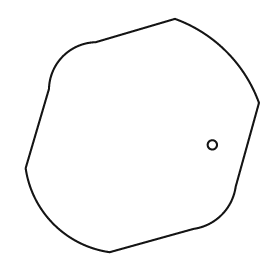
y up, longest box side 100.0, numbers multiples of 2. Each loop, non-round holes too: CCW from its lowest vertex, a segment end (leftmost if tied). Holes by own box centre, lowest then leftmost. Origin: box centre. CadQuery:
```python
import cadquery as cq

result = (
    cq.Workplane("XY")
    .moveTo(-14.0, -50.0)
    .lineTo(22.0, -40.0)
    .threePointArc((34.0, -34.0), (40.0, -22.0))
    .lineTo(50.0, 14.0)
    .threePointArc((36.0, 36.0), (14.0, 50.0))
    .lineTo(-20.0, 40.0)
    .threePointArc((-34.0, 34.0), (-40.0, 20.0))
    .lineTo(-50.0, -14.0)
    .threePointArc((-38.0, -38.0), (-14.0, -50.0))
    .close()
    .moveTo(30.0, -4.0)
    .circle(2.0)
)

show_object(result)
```